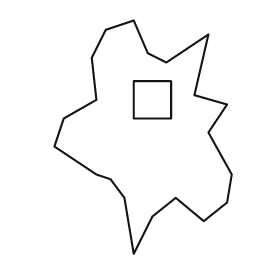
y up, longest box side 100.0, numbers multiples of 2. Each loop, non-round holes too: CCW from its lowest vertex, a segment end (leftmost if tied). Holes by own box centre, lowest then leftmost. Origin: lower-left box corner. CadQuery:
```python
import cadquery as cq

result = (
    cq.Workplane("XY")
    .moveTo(34.0, 0.0)
    .lineTo(42.0, 16.0)
    .lineTo(52.0, 24.0)
    .lineTo(64.0, 14.0)
    .lineTo(74.0, 22.0)
    .lineTo(76.0, 34.0)
    .lineTo(66.0, 52.0)
    .lineTo(74.0, 64.0)
    .lineTo(60.0, 68.0)
    .lineTo(66.0, 94.0)
    .lineTo(48.0, 82.0)
    .lineTo(40.0, 86.0)
    .lineTo(34.0, 100.0)
    .lineTo(22.0, 96.0)
    .lineTo(16.0, 84.0)
    .lineTo(18.0, 66.0)
    .lineTo(4.0, 58.0)
    .lineTo(0.0, 46.0)
    .lineTo(18.0, 34.0)
    .lineTo(24.0, 32.0)
    .lineTo(30.0, 24.0)
    .close()
    .moveTo(34.0, 58.0)
    .lineTo(50.0, 58.0)
    .lineTo(50.0, 74.0)
    .lineTo(34.0, 74.0)
    .close()
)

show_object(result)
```